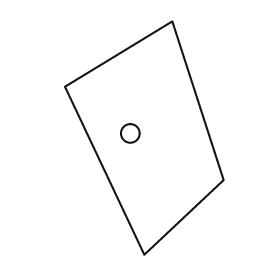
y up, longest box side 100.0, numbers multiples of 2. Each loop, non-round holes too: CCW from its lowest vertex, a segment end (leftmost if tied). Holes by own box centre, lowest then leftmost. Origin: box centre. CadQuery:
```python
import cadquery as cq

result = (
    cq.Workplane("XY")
    .moveTo(0.0, -50.0)
    .lineTo(34.0, -18.0)
    .lineTo(12.0, 50.0)
    .lineTo(-34.0, 22.0)
    .close()
    .moveTo(-6.0, 2.0)
    .circle(4.0)
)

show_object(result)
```